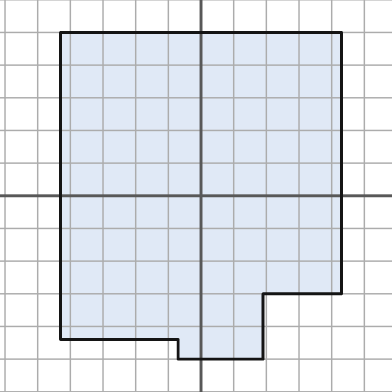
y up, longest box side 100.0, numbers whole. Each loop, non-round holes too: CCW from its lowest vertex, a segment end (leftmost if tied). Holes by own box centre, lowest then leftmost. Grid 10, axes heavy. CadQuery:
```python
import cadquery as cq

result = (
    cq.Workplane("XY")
    .moveTo(-7.0, -50.0)
    .lineTo(19.0, -50.0)
    .lineTo(19.0, -30.0)
    .lineTo(43.0, -30.0)
    .lineTo(43.0, 50.0)
    .lineTo(-43.0, 50.0)
    .lineTo(-43.0, -44.0)
    .lineTo(-7.0, -44.0)
    .close()
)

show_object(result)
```